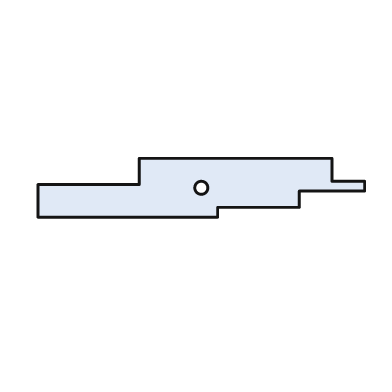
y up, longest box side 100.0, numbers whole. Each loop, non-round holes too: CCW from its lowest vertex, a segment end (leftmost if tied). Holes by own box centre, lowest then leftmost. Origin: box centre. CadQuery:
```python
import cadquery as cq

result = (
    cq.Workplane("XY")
    .moveTo(-50.0, -9.0)
    .lineTo(5.0, -9.0)
    .lineTo(5.0, -6.0)
    .lineTo(30.0, -6.0)
    .lineTo(30.0, -1.0)
    .lineTo(50.0, -1.0)
    .lineTo(50.0, 2.0)
    .lineTo(40.0, 2.0)
    .lineTo(40.0, 9.0)
    .lineTo(-19.0, 9.0)
    .lineTo(-19.0, 1.0)
    .lineTo(-50.0, 1.0)
    .close()
    .moveTo(0.0, 0.0)
    .circle(2.0)
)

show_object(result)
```